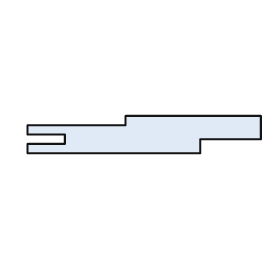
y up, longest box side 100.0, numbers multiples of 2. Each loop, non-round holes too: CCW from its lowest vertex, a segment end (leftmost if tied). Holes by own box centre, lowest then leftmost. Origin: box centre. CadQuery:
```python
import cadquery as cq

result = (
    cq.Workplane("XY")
    .moveTo(-50.0, -8.0)
    .lineTo(24.0, -8.0)
    .lineTo(24.0, -2.0)
    .lineTo(50.0, -2.0)
    .lineTo(50.0, 8.0)
    .lineTo(-8.0, 8.0)
    .lineTo(-8.0, 4.0)
    .lineTo(-50.0, 4.0)
    .lineTo(-50.0, 0.0)
    .lineTo(-34.0, 0.0)
    .lineTo(-34.0, -4.0)
    .lineTo(-50.0, -4.0)
    .close()
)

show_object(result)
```